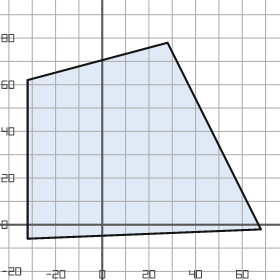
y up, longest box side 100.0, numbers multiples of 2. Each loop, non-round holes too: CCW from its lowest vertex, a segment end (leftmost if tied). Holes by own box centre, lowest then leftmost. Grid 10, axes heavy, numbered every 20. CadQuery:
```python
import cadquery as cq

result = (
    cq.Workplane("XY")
    .moveTo(-32.0, -6.0)
    .lineTo(68.0, -2.0)
    .lineTo(28.0, 78.0)
    .lineTo(-32.0, 62.0)
    .close()
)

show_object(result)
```